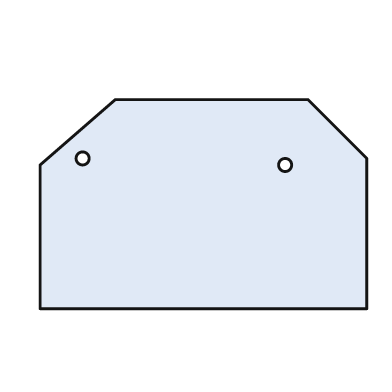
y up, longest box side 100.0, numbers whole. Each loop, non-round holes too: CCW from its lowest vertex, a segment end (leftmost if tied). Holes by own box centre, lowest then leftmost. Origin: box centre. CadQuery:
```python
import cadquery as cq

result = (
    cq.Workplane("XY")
    .moveTo(-50.0, -32.0)
    .lineTo(50.0, -32.0)
    .lineTo(50.0, 14.0)
    .lineTo(32.0, 32.0)
    .lineTo(-27.0, 32.0)
    .lineTo(-50.0, 12.0)
    .close()
    .moveTo(25.0, 12.0)
    .circle(2.0)
    .moveTo(-37.0, 14.0)
    .circle(2.0)
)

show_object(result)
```